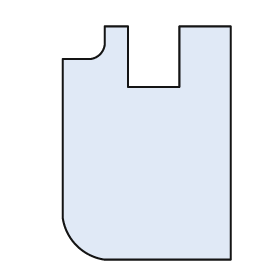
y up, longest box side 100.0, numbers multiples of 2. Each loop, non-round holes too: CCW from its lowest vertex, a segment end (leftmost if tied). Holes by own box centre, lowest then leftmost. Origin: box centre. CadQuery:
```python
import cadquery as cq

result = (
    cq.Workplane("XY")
    .moveTo(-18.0, -50.0)
    .lineTo(36.0, -50.0)
    .lineTo(36.0, 50.0)
    .lineTo(14.0, 50.0)
    .lineTo(14.0, 24.0)
    .lineTo(-8.0, 24.0)
    .lineTo(-8.0, 50.0)
    .lineTo(-18.0, 50.0)
    .lineTo(-18.0, 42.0)
    .threePointArc((-20.0, 38.0), (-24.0, 36.0))
    .lineTo(-36.0, 36.0)
    .lineTo(-36.0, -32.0)
    .threePointArc((-30.0, -44.0), (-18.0, -50.0))
    .close()
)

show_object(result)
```